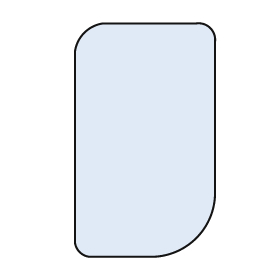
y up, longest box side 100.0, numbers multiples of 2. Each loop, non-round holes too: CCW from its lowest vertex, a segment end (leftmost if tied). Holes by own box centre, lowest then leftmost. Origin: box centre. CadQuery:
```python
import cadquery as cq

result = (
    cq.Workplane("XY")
    .moveTo(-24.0, -50.0)
    .lineTo(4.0, -50.0)
    .threePointArc((22.0, -42.0), (30.0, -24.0))
    .lineTo(30.0, 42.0)
    .threePointArc((28.0, 48.0), (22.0, 50.0))
    .lineTo(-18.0, 50.0)
    .threePointArc((-26.0, 46.0), (-30.0, 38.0))
    .lineTo(-30.0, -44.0)
    .threePointArc((-28.0, -48.0), (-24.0, -50.0))
    .close()
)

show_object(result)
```